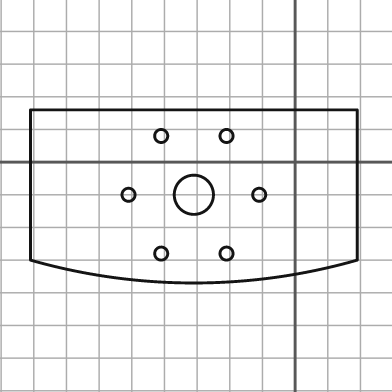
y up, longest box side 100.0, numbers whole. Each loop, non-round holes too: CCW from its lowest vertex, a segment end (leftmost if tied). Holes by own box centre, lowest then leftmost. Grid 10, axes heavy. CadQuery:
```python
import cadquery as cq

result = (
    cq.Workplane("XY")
    .moveTo(-81.0, -30.0)
    .threePointArc((-31.0, -37.0), (19.0, -30.0))
    .lineTo(19.0, 16.0)
    .lineTo(-81.0, 16.0)
    .close()
    .moveTo(-41.0, -28.0)
    .circle(2.0)
    .moveTo(-21.0, -28.0)
    .circle(2.0)
    .moveTo(-51.0, -10.0)
    .circle(2.0)
    .moveTo(-31.0, -10.0)
    .circle(6.0)
    .moveTo(-11.0, -10.0)
    .circle(2.0)
    .moveTo(-41.0, 8.0)
    .circle(2.0)
    .moveTo(-21.0, 8.0)
    .circle(2.0)
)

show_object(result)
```